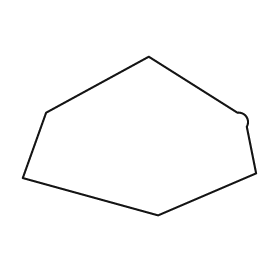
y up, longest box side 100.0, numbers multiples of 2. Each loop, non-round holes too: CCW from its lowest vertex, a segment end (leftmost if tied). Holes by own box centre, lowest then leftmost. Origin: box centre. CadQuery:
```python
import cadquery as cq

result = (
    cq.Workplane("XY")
    .moveTo(8.0, -34.0)
    .lineTo(50.0, -16.0)
    .lineTo(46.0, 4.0)
    .threePointArc((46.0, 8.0), (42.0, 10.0))
    .lineTo(4.0, 34.0)
    .lineTo(-40.0, 10.0)
    .lineTo(-50.0, -18.0)
    .close()
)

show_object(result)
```